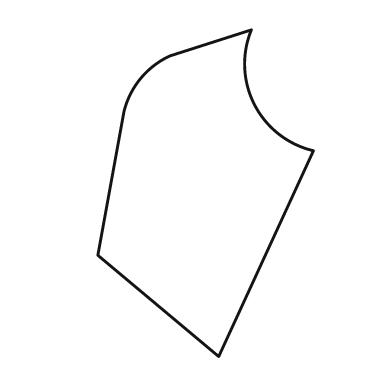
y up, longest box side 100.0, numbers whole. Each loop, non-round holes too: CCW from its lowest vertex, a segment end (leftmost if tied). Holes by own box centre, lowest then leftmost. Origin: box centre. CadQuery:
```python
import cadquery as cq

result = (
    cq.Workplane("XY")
    .moveTo(4.0, -50.0)
    .lineTo(33.0, 13.0)
    .threePointArc((15.0, 27.0), (14.0, 50.0))
    .lineTo(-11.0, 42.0)
    .threePointArc((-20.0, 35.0), (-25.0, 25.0))
    .lineTo(-33.0, -19.0)
    .close()
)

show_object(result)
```